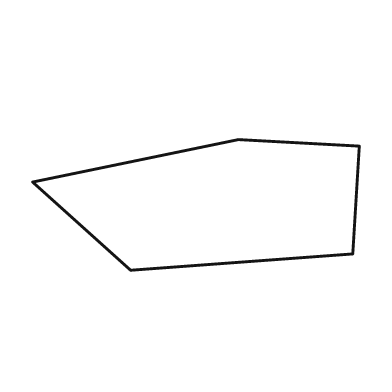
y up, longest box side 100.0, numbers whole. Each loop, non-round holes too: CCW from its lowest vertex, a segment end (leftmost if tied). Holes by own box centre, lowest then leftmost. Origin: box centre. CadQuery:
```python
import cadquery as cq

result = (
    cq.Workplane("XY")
    .moveTo(-20.0, -20.0)
    .lineTo(48.0, -15.0)
    .lineTo(50.0, 18.0)
    .lineTo(13.0, 20.0)
    .lineTo(-50.0, 7.0)
    .close()
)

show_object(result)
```